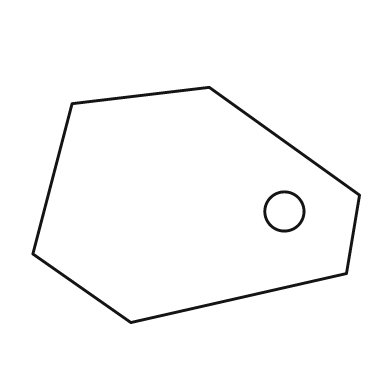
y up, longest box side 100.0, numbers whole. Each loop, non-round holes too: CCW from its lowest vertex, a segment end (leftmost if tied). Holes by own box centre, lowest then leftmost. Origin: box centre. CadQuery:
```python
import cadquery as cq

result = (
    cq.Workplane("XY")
    .moveTo(-20.0, -36.0)
    .lineTo(46.0, -21.0)
    .lineTo(50.0, 3.0)
    .lineTo(4.0, 36.0)
    .lineTo(-38.0, 31.0)
    .lineTo(-50.0, -15.0)
    .close()
    .moveTo(27.0, -2.0)
    .circle(6.0)
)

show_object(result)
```